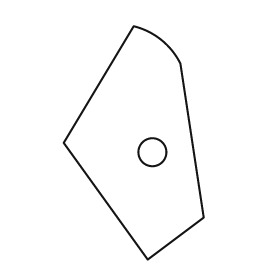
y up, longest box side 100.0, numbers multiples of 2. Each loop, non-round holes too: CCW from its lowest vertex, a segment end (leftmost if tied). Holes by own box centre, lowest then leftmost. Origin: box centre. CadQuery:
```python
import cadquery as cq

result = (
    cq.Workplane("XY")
    .moveTo(6.0, -50.0)
    .lineTo(30.0, -32.0)
    .lineTo(20.0, 34.0)
    .threePointArc((12.0, 44.0), (0.0, 50.0))
    .lineTo(-30.0, 0.0)
    .close()
    .moveTo(8.0, -4.0)
    .circle(6.0)
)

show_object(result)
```